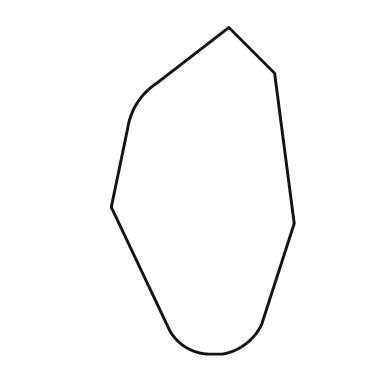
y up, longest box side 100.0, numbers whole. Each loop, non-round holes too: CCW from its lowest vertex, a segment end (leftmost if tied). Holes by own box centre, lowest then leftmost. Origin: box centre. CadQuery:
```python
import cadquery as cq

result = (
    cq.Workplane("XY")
    .moveTo(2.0, -50.0)
    .lineTo(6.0, -50.0)
    .threePointArc((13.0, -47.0), (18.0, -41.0))
    .lineTo(28.0, -10.0)
    .lineTo(22.0, 36.0)
    .lineTo(8.0, 50.0)
    .lineTo(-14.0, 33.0)
    .threePointArc((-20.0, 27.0), (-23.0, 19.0))
    .lineTo(-28.0, -5.0)
    .lineTo(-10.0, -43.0)
    .threePointArc((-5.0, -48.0), (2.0, -50.0))
    .close()
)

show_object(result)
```